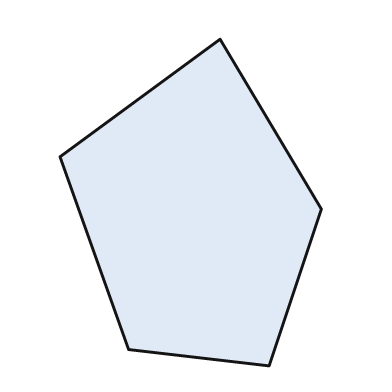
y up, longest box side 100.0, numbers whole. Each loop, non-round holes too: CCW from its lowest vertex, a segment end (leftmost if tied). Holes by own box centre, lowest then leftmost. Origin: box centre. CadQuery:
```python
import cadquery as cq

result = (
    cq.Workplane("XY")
    .moveTo(24.0, -50.0)
    .lineTo(40.0, -2.0)
    .lineTo(9.0, 50.0)
    .lineTo(-40.0, 14.0)
    .lineTo(-19.0, -45.0)
    .close()
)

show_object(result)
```